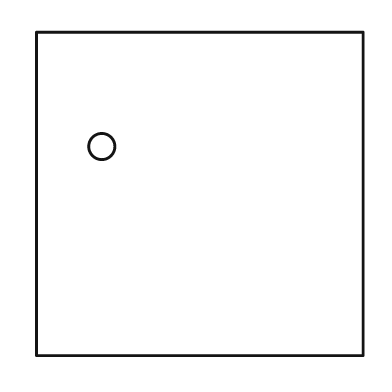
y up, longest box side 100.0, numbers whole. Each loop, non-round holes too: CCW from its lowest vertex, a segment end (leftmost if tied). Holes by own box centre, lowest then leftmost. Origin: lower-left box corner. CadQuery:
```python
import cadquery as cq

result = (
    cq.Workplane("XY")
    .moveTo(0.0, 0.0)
    .lineTo(100.0, 0.0)
    .lineTo(100.0, 99.0)
    .lineTo(0.0, 99.0)
    .close()
    .moveTo(20.0, 64.0)
    .circle(4.0)
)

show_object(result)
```